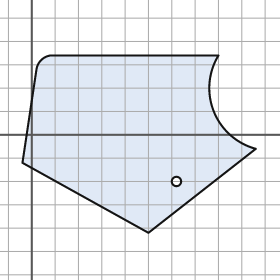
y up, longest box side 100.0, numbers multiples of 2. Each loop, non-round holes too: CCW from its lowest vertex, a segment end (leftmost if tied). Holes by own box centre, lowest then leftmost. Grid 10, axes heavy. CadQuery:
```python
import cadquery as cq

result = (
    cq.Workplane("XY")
    .moveTo(50.0, -42.0)
    .lineTo(96.0, -6.0)
    .threePointArc((78.0, 10.0), (80.0, 34.0))
    .lineTo(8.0, 34.0)
    .threePointArc((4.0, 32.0), (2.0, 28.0))
    .lineTo(-4.0, -12.0)
    .close()
    .moveTo(62.0, -20.0)
    .circle(2.0)
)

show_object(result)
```